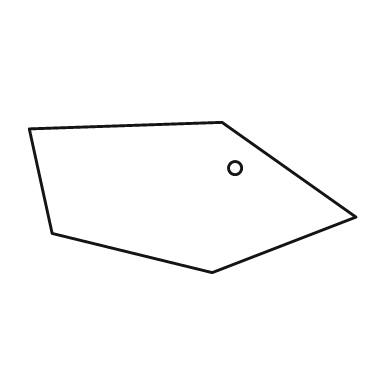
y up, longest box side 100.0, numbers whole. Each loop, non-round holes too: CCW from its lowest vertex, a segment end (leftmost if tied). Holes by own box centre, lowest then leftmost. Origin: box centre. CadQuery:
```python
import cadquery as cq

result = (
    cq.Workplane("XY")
    .moveTo(6.0, -23.0)
    .lineTo(50.0, -6.0)
    .lineTo(9.0, 23.0)
    .lineTo(-50.0, 21.0)
    .lineTo(-43.0, -11.0)
    .close()
    .moveTo(13.0, 9.0)
    .circle(2.0)
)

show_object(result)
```